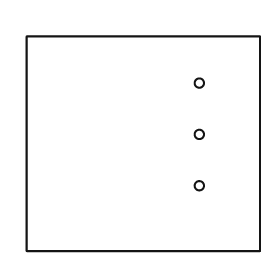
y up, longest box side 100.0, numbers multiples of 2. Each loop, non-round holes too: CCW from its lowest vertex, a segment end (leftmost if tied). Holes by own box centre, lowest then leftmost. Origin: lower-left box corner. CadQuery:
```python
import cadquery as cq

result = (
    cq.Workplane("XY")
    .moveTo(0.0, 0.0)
    .lineTo(100.0, 0.0)
    .lineTo(100.0, 92.0)
    .lineTo(0.0, 92.0)
    .close()
    .moveTo(74.0, 28.0)
    .circle(2.0)
    .moveTo(74.0, 50.0)
    .circle(2.0)
    .moveTo(74.0, 72.0)
    .circle(2.0)
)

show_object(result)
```